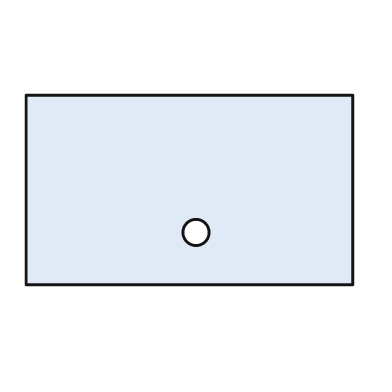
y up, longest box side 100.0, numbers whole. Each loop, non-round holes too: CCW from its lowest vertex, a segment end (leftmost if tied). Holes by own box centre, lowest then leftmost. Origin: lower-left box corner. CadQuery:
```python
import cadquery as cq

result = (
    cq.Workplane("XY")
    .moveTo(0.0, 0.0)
    .lineTo(100.0, 0.0)
    .lineTo(100.0, 58.0)
    .lineTo(0.0, 58.0)
    .close()
    .moveTo(52.0, 16.0)
    .circle(4.0)
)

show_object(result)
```